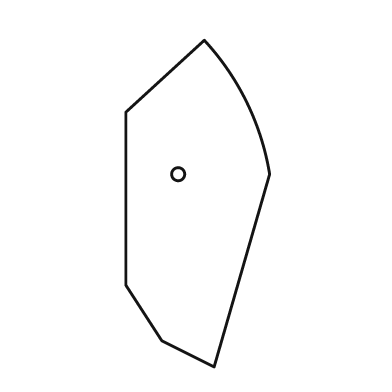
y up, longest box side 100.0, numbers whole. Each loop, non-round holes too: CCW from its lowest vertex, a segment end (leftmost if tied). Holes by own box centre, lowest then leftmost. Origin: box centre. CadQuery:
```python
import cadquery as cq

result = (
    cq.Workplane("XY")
    .moveTo(5.0, -50.0)
    .lineTo(22.0, 9.0)
    .threePointArc((15.0, 31.0), (2.0, 50.0))
    .lineTo(-22.0, 28.0)
    .lineTo(-22.0, -25.0)
    .lineTo(-11.0, -42.0)
    .close()
    .moveTo(-6.0, 9.0)
    .circle(2.0)
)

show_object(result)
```